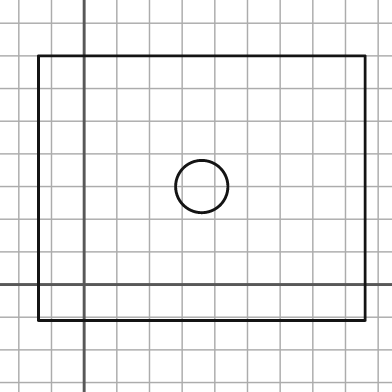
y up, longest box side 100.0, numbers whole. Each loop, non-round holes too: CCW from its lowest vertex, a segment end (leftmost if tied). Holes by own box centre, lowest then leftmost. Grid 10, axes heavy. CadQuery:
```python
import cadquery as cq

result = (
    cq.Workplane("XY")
    .moveTo(-14.0, -11.0)
    .lineTo(86.0, -11.0)
    .lineTo(86.0, 70.0)
    .lineTo(-14.0, 70.0)
    .close()
    .moveTo(36.0, 30.0)
    .circle(8.0)
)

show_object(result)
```